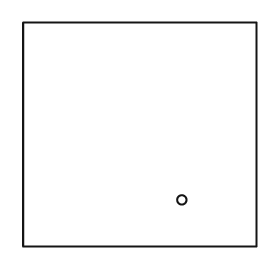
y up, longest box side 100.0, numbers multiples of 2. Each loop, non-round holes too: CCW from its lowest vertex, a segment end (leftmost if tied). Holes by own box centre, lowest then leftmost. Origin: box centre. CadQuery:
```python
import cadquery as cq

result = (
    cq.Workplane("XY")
    .moveTo(-50.0, -48.0)
    .lineTo(50.0, -48.0)
    .lineTo(50.0, 48.0)
    .lineTo(-50.0, 48.0)
    .close()
    .moveTo(18.0, -28.0)
    .circle(2.0)
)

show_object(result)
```